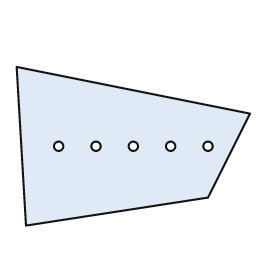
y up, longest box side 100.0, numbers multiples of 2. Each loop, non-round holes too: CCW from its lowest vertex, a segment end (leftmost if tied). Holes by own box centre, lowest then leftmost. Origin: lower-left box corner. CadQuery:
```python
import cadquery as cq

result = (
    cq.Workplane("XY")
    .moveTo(4.0, 0.0)
    .lineTo(82.0, 12.0)
    .lineTo(100.0, 48.0)
    .lineTo(0.0, 68.0)
    .close()
    .moveTo(18.0, 34.0)
    .circle(2.0)
    .moveTo(34.0, 34.0)
    .circle(2.0)
    .moveTo(50.0, 34.0)
    .circle(2.0)
    .moveTo(66.0, 34.0)
    .circle(2.0)
    .moveTo(82.0, 34.0)
    .circle(2.0)
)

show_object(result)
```